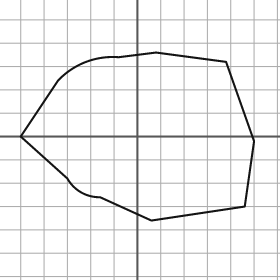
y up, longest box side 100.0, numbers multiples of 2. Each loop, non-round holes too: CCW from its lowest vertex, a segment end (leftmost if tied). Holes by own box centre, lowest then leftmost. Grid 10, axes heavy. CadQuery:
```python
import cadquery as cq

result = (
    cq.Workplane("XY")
    .moveTo(6.0, -36.0)
    .lineTo(46.0, -30.0)
    .lineTo(50.0, -2.0)
    .lineTo(38.0, 32.0)
    .lineTo(8.0, 36.0)
    .lineTo(-8.0, 34.0)
    .threePointArc((-22.0, 32.0), (-34.0, 24.0))
    .lineTo(-50.0, 0.0)
    .lineTo(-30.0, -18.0)
    .threePointArc((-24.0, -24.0), (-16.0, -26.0))
    .close()
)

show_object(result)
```